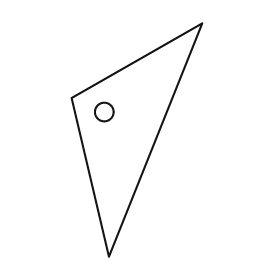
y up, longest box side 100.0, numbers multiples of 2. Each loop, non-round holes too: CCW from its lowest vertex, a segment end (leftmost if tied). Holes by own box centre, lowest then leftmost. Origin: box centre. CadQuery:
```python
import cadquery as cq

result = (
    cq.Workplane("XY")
    .moveTo(-12.0, -50.0)
    .lineTo(28.0, 50.0)
    .lineTo(-28.0, 18.0)
    .close()
    .moveTo(-14.0, 12.0)
    .circle(4.0)
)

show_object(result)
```